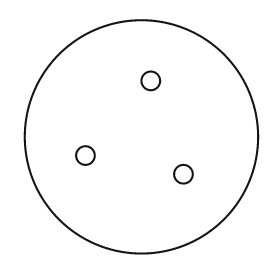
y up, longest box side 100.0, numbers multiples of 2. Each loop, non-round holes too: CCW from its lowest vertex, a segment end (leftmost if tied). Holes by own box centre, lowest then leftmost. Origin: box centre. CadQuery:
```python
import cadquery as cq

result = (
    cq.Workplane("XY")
    .moveTo(0.0, 0.0)
    .circle(50.0)
    .moveTo(18.0, -16.0)
    .circle(4.0)
    .moveTo(-24.0, -8.0)
    .circle(4.0)
    .moveTo(4.0, 24.0)
    .circle(4.0)
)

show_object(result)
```